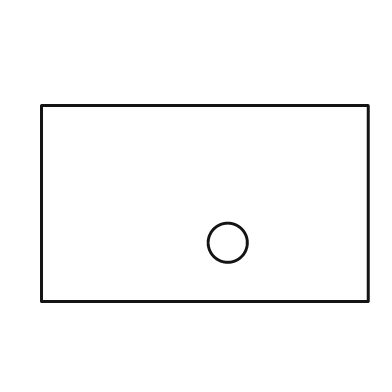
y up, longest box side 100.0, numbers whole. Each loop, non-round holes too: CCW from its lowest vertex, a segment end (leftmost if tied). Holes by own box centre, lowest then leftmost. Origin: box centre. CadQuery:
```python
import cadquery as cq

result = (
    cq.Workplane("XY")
    .moveTo(-50.0, -30.0)
    .lineTo(50.0, -30.0)
    .lineTo(50.0, 30.0)
    .lineTo(-50.0, 30.0)
    .close()
    .moveTo(7.0, -12.0)
    .circle(6.0)
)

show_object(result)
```